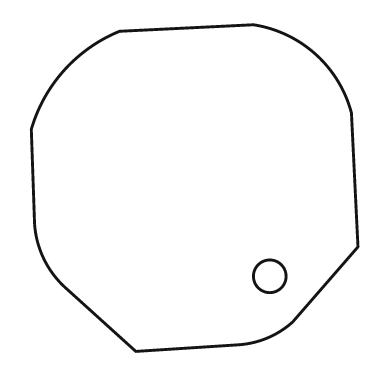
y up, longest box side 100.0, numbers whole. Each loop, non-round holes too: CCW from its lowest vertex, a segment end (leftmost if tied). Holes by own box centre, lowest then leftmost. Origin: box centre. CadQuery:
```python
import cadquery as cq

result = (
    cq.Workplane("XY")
    .moveTo(-18.0, -50.0)
    .lineTo(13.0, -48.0)
    .threePointArc((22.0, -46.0), (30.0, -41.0))
    .lineTo(50.0, -18.0)
    .lineTo(48.0, 23.0)
    .threePointArc((37.0, 41.0), (18.0, 50.0))
    .lineTo(-23.0, 48.0)
    .threePointArc((-40.0, 36.0), (-50.0, 18.0))
    .lineTo(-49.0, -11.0)
    .threePointArc((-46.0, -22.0), (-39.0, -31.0))
    .close()
    .moveTo(23.0, -27.0)
    .circle(5.0)
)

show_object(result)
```